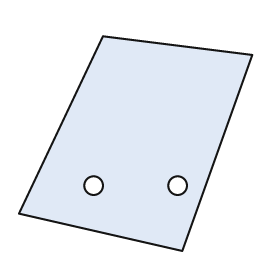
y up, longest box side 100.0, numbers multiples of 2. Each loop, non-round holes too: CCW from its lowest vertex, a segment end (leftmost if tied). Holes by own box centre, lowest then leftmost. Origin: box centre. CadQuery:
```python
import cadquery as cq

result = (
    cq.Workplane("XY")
    .moveTo(20.0, -46.0)
    .lineTo(50.0, 38.0)
    .lineTo(-14.0, 46.0)
    .lineTo(-50.0, -30.0)
    .close()
    .moveTo(-18.0, -18.0)
    .circle(4.0)
    .moveTo(18.0, -18.0)
    .circle(4.0)
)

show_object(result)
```